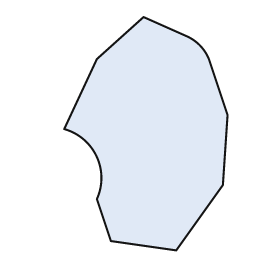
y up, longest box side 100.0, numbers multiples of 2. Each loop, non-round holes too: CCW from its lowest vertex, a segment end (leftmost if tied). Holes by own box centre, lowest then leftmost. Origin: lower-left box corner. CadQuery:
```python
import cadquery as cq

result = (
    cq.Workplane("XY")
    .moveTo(48.0, 0.0)
    .lineTo(68.0, 28.0)
    .lineTo(70.0, 58.0)
    .lineTo(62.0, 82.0)
    .threePointArc((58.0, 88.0), (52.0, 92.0))
    .lineTo(34.0, 100.0)
    .lineTo(14.0, 82.0)
    .lineTo(0.0, 52.0)
    .threePointArc((14.0, 40.0), (14.0, 22.0))
    .lineTo(20.0, 4.0)
    .close()
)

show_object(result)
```